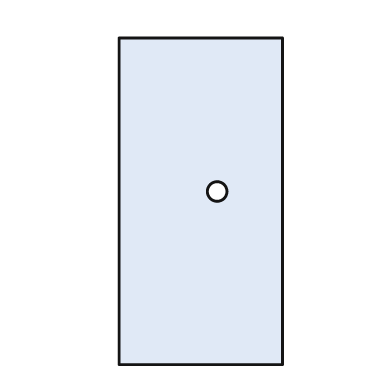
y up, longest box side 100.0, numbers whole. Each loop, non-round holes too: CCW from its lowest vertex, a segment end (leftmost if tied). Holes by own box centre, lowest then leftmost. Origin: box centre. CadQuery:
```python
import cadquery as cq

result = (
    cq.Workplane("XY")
    .moveTo(-25.0, -50.0)
    .lineTo(25.0, -50.0)
    .lineTo(25.0, 50.0)
    .lineTo(-25.0, 50.0)
    .close()
    .moveTo(5.0, 3.0)
    .circle(3.0)
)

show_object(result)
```